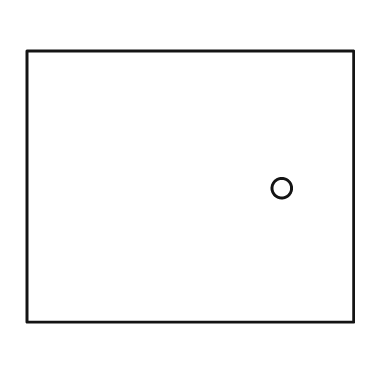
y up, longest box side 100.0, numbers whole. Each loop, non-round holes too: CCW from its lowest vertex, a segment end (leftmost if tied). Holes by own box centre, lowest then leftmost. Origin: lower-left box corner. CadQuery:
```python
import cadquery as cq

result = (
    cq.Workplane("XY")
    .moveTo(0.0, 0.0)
    .lineTo(100.0, 0.0)
    .lineTo(100.0, 83.0)
    .lineTo(0.0, 83.0)
    .close()
    .moveTo(78.0, 41.0)
    .circle(3.0)
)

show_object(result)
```